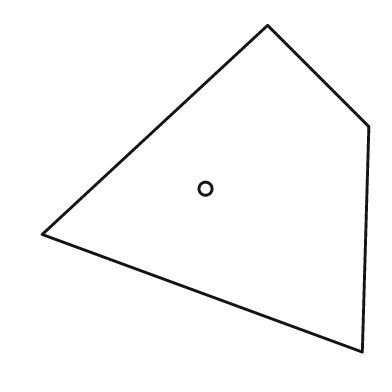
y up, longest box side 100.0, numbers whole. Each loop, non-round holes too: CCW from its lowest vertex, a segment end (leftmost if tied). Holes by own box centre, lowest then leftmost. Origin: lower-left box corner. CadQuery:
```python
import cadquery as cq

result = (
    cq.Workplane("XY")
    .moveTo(98.0, 0.0)
    .lineTo(100.0, 69.0)
    .lineTo(69.0, 100.0)
    .lineTo(0.0, 36.0)
    .close()
    .moveTo(50.0, 50.0)
    .circle(2.0)
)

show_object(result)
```